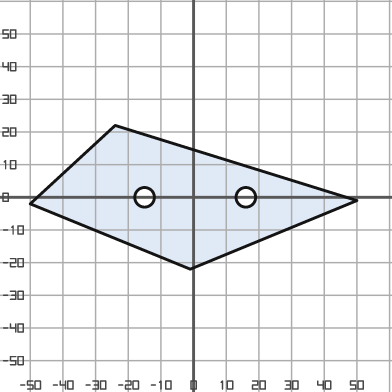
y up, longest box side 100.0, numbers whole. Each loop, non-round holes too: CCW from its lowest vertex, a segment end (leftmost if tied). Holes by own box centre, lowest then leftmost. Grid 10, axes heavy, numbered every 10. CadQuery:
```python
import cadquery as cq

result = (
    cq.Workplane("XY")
    .moveTo(-1.0, -22.0)
    .lineTo(50.0, -1.0)
    .lineTo(-24.0, 22.0)
    .lineTo(-50.0, -2.0)
    .close()
    .moveTo(-15.0, 0.0)
    .circle(3.0)
    .moveTo(16.0, 0.0)
    .circle(3.0)
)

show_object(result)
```